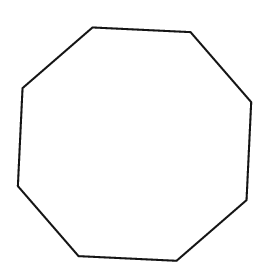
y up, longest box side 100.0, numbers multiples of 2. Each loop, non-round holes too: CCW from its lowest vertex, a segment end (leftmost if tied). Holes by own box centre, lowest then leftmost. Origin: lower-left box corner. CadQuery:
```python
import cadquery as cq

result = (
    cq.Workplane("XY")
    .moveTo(68.0, 0.0)
    .lineTo(98.0, 26.0)
    .lineTo(100.0, 68.0)
    .lineTo(74.0, 98.0)
    .lineTo(32.0, 100.0)
    .lineTo(2.0, 74.0)
    .lineTo(0.0, 32.0)
    .lineTo(26.0, 2.0)
    .close()
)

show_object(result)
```